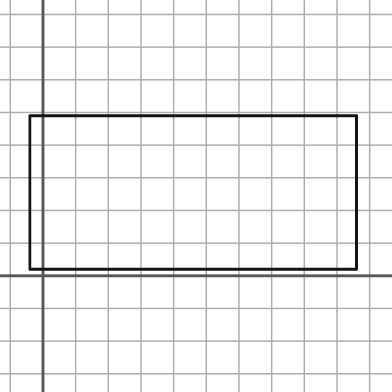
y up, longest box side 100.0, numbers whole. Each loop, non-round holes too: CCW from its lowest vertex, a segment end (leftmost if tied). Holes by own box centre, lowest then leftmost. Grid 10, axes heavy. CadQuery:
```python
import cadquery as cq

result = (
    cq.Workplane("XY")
    .moveTo(-4.0, 2.0)
    .lineTo(96.0, 2.0)
    .lineTo(96.0, 49.0)
    .lineTo(-4.0, 49.0)
    .close()
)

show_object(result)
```